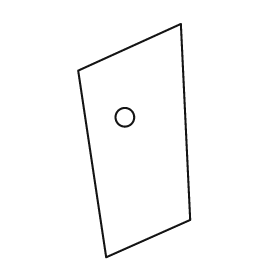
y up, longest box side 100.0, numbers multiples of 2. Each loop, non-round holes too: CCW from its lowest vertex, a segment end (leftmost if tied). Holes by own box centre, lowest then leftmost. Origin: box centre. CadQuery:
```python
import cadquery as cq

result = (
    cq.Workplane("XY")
    .moveTo(-12.0, -50.0)
    .lineTo(24.0, -34.0)
    .lineTo(20.0, 50.0)
    .lineTo(-24.0, 30.0)
    .close()
    .moveTo(-4.0, 10.0)
    .circle(4.0)
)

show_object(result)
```